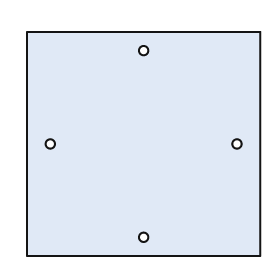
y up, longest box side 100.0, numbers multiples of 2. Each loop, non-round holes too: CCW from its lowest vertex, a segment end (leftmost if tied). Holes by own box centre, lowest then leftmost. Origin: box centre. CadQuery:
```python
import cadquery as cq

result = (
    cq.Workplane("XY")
    .moveTo(-50.0, -48.0)
    .lineTo(50.0, -48.0)
    .lineTo(50.0, 48.0)
    .lineTo(-50.0, 48.0)
    .close()
    .moveTo(0.0, -40.0)
    .circle(2.0)
    .moveTo(-40.0, 0.0)
    .circle(2.0)
    .moveTo(40.0, 0.0)
    .circle(2.0)
    .moveTo(0.0, 40.0)
    .circle(2.0)
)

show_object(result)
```